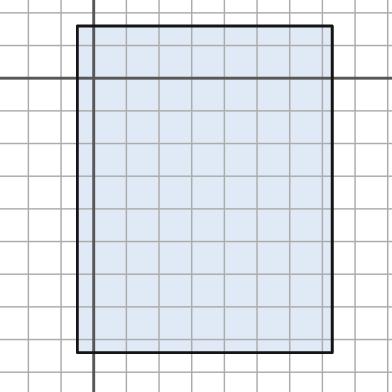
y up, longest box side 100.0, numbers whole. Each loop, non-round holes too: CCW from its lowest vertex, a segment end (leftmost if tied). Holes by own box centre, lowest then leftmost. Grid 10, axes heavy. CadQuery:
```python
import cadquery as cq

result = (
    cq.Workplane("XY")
    .moveTo(-5.0, -84.0)
    .lineTo(73.0, -84.0)
    .lineTo(73.0, 16.0)
    .lineTo(-5.0, 16.0)
    .close()
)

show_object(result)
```